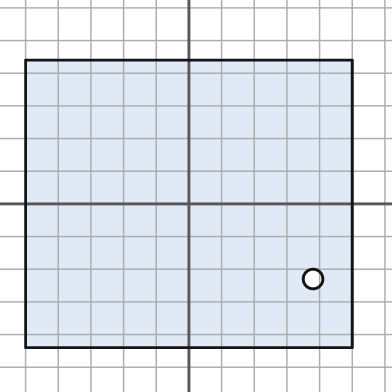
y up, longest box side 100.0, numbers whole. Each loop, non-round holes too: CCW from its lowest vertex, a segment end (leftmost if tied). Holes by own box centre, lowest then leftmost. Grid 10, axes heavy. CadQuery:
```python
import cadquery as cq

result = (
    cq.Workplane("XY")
    .moveTo(-50.0, -44.0)
    .lineTo(50.0, -44.0)
    .lineTo(50.0, 44.0)
    .lineTo(-50.0, 44.0)
    .close()
    .moveTo(38.0, -23.0)
    .circle(3.0)
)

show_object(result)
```